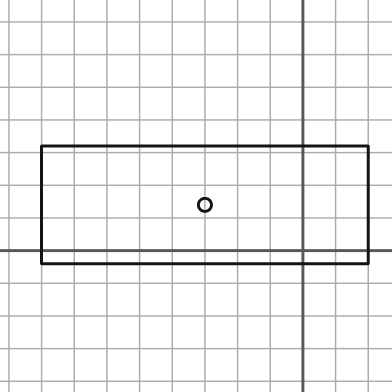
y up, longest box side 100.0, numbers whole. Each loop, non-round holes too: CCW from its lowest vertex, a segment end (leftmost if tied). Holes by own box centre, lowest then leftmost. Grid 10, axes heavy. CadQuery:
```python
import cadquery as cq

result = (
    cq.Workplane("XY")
    .moveTo(-80.0, -4.0)
    .lineTo(20.0, -4.0)
    .lineTo(20.0, 32.0)
    .lineTo(-80.0, 32.0)
    .close()
    .moveTo(-30.0, 14.0)
    .circle(2.0)
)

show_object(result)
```